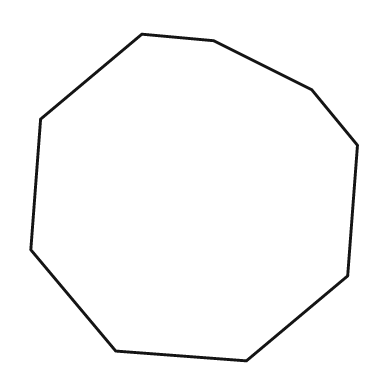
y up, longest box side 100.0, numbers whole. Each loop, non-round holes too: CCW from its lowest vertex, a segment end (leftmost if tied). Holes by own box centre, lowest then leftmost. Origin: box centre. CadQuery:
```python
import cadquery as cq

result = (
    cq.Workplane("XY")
    .moveTo(16.0, -50.0)
    .lineTo(47.0, -24.0)
    .lineTo(50.0, 16.0)
    .lineTo(36.0, 33.0)
    .lineTo(6.0, 48.0)
    .lineTo(-16.0, 50.0)
    .lineTo(-47.0, 24.0)
    .lineTo(-50.0, -16.0)
    .lineTo(-24.0, -47.0)
    .close()
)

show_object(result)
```